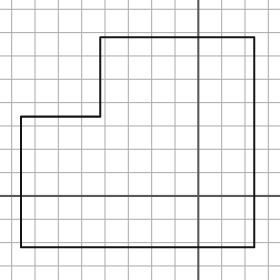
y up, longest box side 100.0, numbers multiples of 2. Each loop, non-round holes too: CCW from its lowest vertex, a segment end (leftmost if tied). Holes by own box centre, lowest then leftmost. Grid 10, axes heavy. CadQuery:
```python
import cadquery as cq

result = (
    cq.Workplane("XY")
    .moveTo(-76.0, -22.0)
    .lineTo(24.0, -22.0)
    .lineTo(24.0, 68.0)
    .lineTo(-42.0, 68.0)
    .lineTo(-42.0, 34.0)
    .lineTo(-76.0, 34.0)
    .close()
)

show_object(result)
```